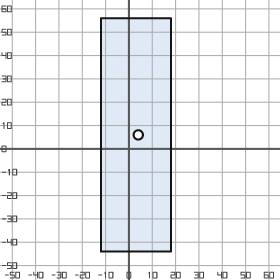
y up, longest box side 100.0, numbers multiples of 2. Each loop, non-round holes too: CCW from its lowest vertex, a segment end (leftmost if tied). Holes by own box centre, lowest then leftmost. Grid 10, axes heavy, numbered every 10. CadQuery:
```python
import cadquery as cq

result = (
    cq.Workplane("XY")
    .moveTo(-12.0, -44.0)
    .lineTo(18.0, -44.0)
    .lineTo(18.0, 56.0)
    .lineTo(-12.0, 56.0)
    .close()
    .moveTo(4.0, 6.0)
    .circle(2.0)
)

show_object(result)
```